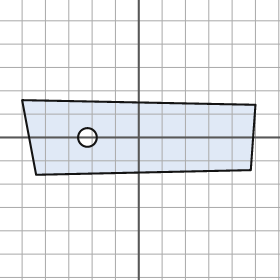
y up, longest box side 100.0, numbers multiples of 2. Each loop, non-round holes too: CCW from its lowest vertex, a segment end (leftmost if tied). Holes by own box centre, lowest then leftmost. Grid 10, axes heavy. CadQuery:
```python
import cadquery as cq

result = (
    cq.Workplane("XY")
    .moveTo(-44.0, -16.0)
    .lineTo(48.0, -14.0)
    .lineTo(50.0, 14.0)
    .lineTo(-50.0, 16.0)
    .close()
    .moveTo(-22.0, 0.0)
    .circle(4.0)
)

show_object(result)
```